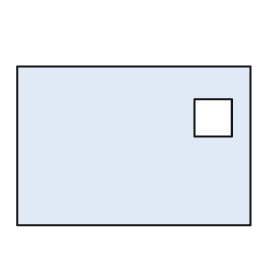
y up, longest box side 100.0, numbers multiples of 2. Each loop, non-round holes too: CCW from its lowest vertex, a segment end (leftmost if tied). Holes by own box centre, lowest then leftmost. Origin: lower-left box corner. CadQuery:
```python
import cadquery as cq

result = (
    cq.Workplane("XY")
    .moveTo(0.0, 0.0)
    .lineTo(100.0, 0.0)
    .lineTo(100.0, 68.0)
    .lineTo(0.0, 68.0)
    .close()
    .moveTo(76.0, 38.0)
    .lineTo(92.0, 38.0)
    .lineTo(92.0, 54.0)
    .lineTo(76.0, 54.0)
    .close()
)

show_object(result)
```